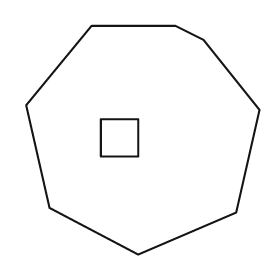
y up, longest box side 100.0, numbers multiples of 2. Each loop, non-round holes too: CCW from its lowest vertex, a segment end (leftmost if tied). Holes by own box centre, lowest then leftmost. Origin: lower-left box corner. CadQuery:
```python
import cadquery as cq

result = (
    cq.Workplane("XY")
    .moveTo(48.0, 0.0)
    .lineTo(90.0, 18.0)
    .lineTo(100.0, 62.0)
    .lineTo(76.0, 92.0)
    .lineTo(64.0, 98.0)
    .lineTo(28.0, 98.0)
    .lineTo(0.0, 64.0)
    .lineTo(10.0, 20.0)
    .close()
    .moveTo(32.0, 42.0)
    .lineTo(48.0, 42.0)
    .lineTo(48.0, 58.0)
    .lineTo(32.0, 58.0)
    .close()
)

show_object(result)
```